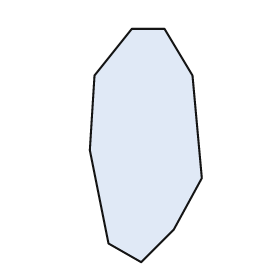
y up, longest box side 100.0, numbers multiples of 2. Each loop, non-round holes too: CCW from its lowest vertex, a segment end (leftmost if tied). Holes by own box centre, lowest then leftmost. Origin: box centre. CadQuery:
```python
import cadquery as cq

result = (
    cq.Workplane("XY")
    .moveTo(-2.0, -50.0)
    .lineTo(12.0, -36.0)
    .lineTo(24.0, -14.0)
    .lineTo(20.0, 30.0)
    .lineTo(8.0, 50.0)
    .lineTo(-6.0, 50.0)
    .lineTo(-22.0, 30.0)
    .lineTo(-24.0, -2.0)
    .lineTo(-16.0, -42.0)
    .close()
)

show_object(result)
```